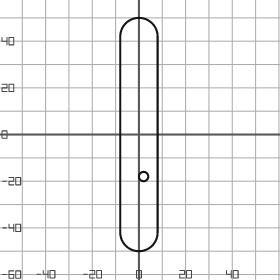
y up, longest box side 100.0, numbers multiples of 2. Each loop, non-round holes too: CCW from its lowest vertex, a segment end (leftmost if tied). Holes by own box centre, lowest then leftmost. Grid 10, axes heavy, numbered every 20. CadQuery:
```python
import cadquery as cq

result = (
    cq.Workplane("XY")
    .moveTo(-8.0, -42.0)
    .threePointArc((0.0, -50.0), (8.0, -42.0))
    .lineTo(8.0, 42.0)
    .threePointArc((0.0, 50.0), (-8.0, 42.0))
    .close()
    .moveTo(2.0, -18.0)
    .circle(2.0)
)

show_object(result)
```